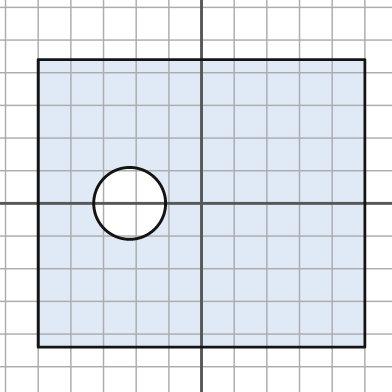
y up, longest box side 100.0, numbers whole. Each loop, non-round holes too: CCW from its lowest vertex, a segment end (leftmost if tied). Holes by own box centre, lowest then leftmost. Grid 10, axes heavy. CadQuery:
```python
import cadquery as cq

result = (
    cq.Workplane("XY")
    .moveTo(-50.0, -44.0)
    .lineTo(50.0, -44.0)
    .lineTo(50.0, 44.0)
    .lineTo(-50.0, 44.0)
    .close()
    .moveTo(-22.0, 0.0)
    .circle(11.0)
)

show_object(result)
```